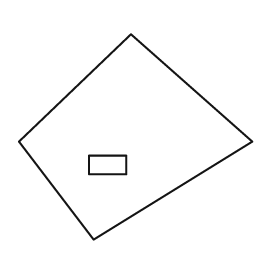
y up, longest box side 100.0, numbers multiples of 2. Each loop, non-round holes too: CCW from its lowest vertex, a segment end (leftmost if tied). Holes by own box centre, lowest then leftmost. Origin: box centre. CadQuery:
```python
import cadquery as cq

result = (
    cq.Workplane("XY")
    .moveTo(-18.0, -44.0)
    .lineTo(50.0, -2.0)
    .lineTo(-2.0, 44.0)
    .lineTo(-50.0, -2.0)
    .close()
    .moveTo(-20.0, -16.0)
    .lineTo(-4.0, -16.0)
    .lineTo(-4.0, -8.0)
    .lineTo(-20.0, -8.0)
    .close()
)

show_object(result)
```